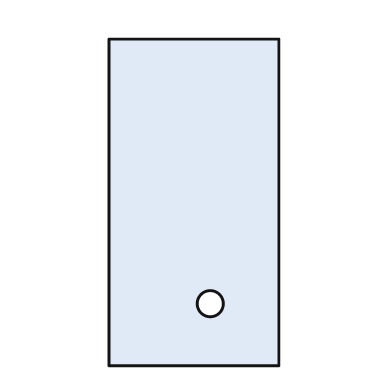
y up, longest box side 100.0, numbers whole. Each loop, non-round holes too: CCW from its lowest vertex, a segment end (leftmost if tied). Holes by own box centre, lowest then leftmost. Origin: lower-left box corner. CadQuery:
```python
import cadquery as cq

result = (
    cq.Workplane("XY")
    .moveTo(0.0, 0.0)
    .lineTo(52.0, 0.0)
    .lineTo(52.0, 100.0)
    .lineTo(0.0, 100.0)
    .close()
    .moveTo(31.0, 19.0)
    .circle(4.0)
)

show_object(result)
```